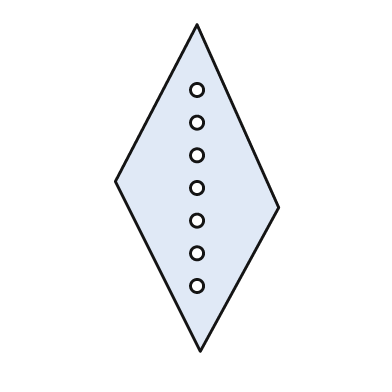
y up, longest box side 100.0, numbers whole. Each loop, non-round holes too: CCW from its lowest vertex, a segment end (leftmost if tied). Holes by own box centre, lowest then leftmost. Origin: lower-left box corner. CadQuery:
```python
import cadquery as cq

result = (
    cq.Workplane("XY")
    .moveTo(26.0, 0.0)
    .lineTo(50.0, 44.0)
    .lineTo(25.0, 100.0)
    .lineTo(0.0, 52.0)
    .close()
    .moveTo(25.0, 20.0)
    .circle(2.0)
    .moveTo(25.0, 30.0)
    .circle(2.0)
    .moveTo(25.0, 40.0)
    .circle(2.0)
    .moveTo(25.0, 50.0)
    .circle(2.0)
    .moveTo(25.0, 60.0)
    .circle(2.0)
    .moveTo(25.0, 70.0)
    .circle(2.0)
    .moveTo(25.0, 80.0)
    .circle(2.0)
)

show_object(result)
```